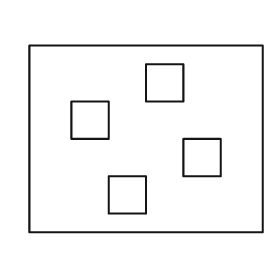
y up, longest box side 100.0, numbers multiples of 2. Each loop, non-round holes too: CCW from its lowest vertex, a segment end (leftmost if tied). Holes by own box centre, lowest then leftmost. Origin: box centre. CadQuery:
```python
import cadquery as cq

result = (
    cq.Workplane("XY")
    .moveTo(-50.0, -40.0)
    .lineTo(50.0, -40.0)
    .lineTo(50.0, 40.0)
    .lineTo(-50.0, 40.0)
    .close()
    .moveTo(-16.0, -32.0)
    .lineTo(0.0, -32.0)
    .lineTo(0.0, -16.0)
    .lineTo(-16.0, -16.0)
    .close()
    .moveTo(16.0, -16.0)
    .lineTo(32.0, -16.0)
    .lineTo(32.0, 0.0)
    .lineTo(16.0, 0.0)
    .close()
    .moveTo(-32.0, 0.0)
    .lineTo(-16.0, 0.0)
    .lineTo(-16.0, 16.0)
    .lineTo(-32.0, 16.0)
    .close()
    .moveTo(0.0, 16.0)
    .lineTo(16.0, 16.0)
    .lineTo(16.0, 32.0)
    .lineTo(0.0, 32.0)
    .close()
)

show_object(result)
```